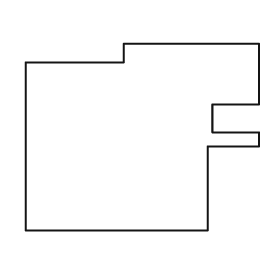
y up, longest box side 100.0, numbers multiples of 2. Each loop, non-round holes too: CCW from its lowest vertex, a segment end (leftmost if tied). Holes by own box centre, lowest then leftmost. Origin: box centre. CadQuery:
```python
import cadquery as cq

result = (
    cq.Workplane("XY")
    .moveTo(-50.0, -40.0)
    .lineTo(28.0, -40.0)
    .lineTo(28.0, -4.0)
    .lineTo(50.0, -4.0)
    .lineTo(50.0, 2.0)
    .lineTo(30.0, 2.0)
    .lineTo(30.0, 14.0)
    .lineTo(50.0, 14.0)
    .lineTo(50.0, 40.0)
    .lineTo(-8.0, 40.0)
    .lineTo(-8.0, 32.0)
    .lineTo(-50.0, 32.0)
    .close()
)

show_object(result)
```